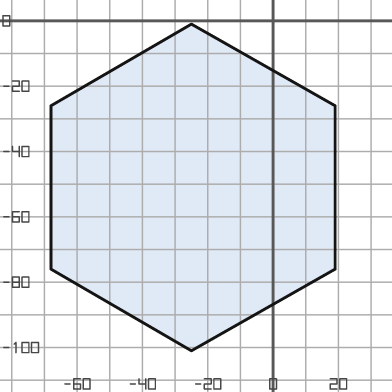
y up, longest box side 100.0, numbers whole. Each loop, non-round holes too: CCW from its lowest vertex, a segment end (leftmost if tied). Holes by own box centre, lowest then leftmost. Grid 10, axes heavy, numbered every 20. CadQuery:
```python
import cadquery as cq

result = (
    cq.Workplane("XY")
    .moveTo(-25.0, -101.0)
    .lineTo(19.0, -76.0)
    .lineTo(19.0, -26.0)
    .lineTo(-25.0, -1.0)
    .lineTo(-68.0, -26.0)
    .lineTo(-68.0, -76.0)
    .close()
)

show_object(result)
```